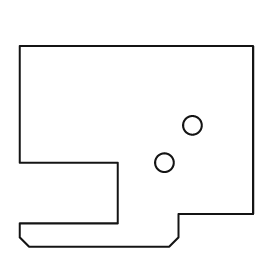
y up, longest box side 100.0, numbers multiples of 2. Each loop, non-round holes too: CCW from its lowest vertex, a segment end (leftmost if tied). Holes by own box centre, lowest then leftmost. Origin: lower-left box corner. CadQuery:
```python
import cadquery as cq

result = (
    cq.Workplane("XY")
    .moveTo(4.0, 0.0)
    .lineTo(64.0, 0.0)
    .lineTo(68.0, 4.0)
    .lineTo(68.0, 14.0)
    .lineTo(100.0, 14.0)
    .lineTo(100.0, 86.0)
    .lineTo(0.0, 86.0)
    .lineTo(0.0, 36.0)
    .lineTo(42.0, 36.0)
    .lineTo(42.0, 10.0)
    .lineTo(0.0, 10.0)
    .lineTo(0.0, 4.0)
    .close()
    .moveTo(62.0, 36.0)
    .circle(4.0)
    .moveTo(74.0, 52.0)
    .circle(4.0)
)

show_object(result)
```